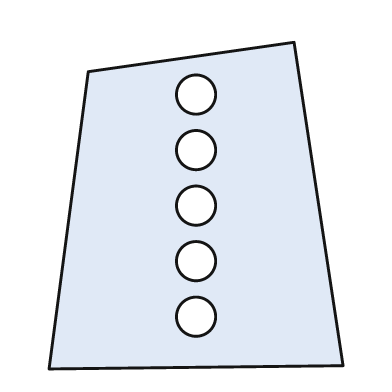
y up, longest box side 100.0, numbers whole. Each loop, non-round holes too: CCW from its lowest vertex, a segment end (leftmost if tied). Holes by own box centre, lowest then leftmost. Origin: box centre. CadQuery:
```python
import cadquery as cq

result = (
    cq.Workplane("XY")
    .moveTo(-45.0, -50.0)
    .lineTo(45.0, -49.0)
    .lineTo(30.0, 50.0)
    .lineTo(-33.0, 41.0)
    .close()
    .moveTo(0.0, -34.0)
    .circle(6.0)
    .moveTo(0.0, -17.0)
    .circle(6.0)
    .moveTo(0.0, 0.0)
    .circle(6.0)
    .moveTo(0.0, 17.0)
    .circle(6.0)
    .moveTo(0.0, 34.0)
    .circle(6.0)
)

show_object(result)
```